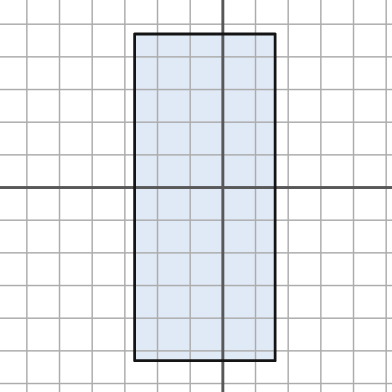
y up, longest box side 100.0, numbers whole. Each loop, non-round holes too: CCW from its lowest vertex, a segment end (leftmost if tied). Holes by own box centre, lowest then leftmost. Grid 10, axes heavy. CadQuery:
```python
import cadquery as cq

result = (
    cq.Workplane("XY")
    .moveTo(-27.0, -53.0)
    .lineTo(16.0, -53.0)
    .lineTo(16.0, 47.0)
    .lineTo(-27.0, 47.0)
    .close()
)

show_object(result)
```